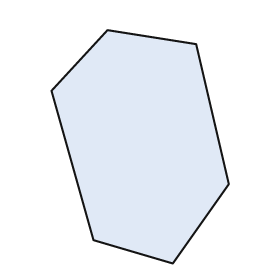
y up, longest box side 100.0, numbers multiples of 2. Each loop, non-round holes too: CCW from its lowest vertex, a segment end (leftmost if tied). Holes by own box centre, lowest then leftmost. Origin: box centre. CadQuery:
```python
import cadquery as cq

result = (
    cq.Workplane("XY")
    .moveTo(14.0, -50.0)
    .lineTo(38.0, -16.0)
    .lineTo(24.0, 44.0)
    .lineTo(-14.0, 50.0)
    .lineTo(-38.0, 24.0)
    .lineTo(-20.0, -40.0)
    .close()
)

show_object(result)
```